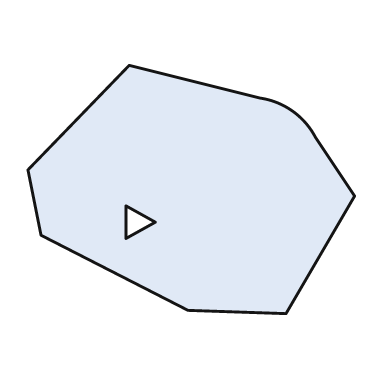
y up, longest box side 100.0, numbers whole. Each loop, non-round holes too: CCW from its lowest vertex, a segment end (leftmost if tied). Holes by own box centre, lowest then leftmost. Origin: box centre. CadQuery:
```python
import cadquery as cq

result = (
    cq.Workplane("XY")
    .moveTo(29.0, -38.0)
    .lineTo(50.0, -2.0)
    .lineTo(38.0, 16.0)
    .threePointArc((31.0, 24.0), (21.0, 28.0))
    .lineTo(-19.0, 38.0)
    .lineTo(-50.0, 6.0)
    .lineTo(-46.0, -14.0)
    .lineTo(-1.0, -37.0)
    .close()
    .moveTo(-20.0, -15.0)
    .lineTo(-11.0, -10.0)
    .lineTo(-20.0, -5.0)
    .close()
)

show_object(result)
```